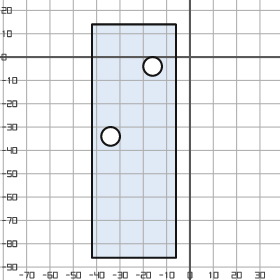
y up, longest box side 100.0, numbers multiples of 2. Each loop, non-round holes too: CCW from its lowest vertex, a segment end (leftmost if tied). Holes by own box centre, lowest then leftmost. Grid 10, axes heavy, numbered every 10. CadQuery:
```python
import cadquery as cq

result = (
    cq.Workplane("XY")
    .moveTo(-42.0, -86.0)
    .lineTo(-6.0, -86.0)
    .lineTo(-6.0, 14.0)
    .lineTo(-42.0, 14.0)
    .close()
    .moveTo(-34.0, -34.0)
    .circle(4.0)
    .moveTo(-16.0, -4.0)
    .circle(4.0)
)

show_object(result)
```